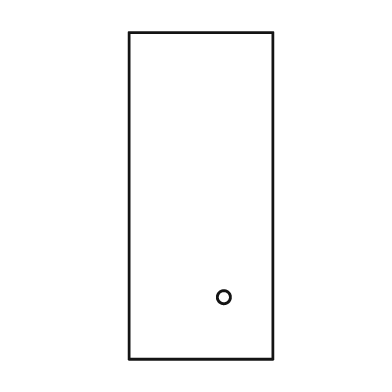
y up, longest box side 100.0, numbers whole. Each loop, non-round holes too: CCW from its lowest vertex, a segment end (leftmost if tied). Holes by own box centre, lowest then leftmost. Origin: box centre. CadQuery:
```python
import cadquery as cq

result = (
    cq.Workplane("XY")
    .moveTo(-22.0, -50.0)
    .lineTo(22.0, -50.0)
    .lineTo(22.0, 50.0)
    .lineTo(-22.0, 50.0)
    .close()
    .moveTo(7.0, -31.0)
    .circle(2.0)
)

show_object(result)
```